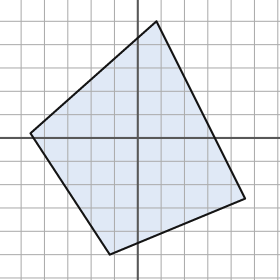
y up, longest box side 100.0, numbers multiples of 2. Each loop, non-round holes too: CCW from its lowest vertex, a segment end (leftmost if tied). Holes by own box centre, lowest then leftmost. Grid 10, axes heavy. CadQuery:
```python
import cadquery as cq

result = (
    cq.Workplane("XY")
    .moveTo(-12.0, -50.0)
    .lineTo(46.0, -26.0)
    .lineTo(8.0, 50.0)
    .lineTo(-46.0, 2.0)
    .close()
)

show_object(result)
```